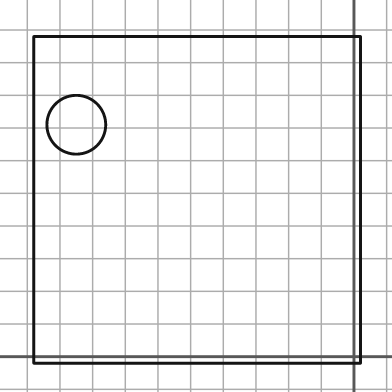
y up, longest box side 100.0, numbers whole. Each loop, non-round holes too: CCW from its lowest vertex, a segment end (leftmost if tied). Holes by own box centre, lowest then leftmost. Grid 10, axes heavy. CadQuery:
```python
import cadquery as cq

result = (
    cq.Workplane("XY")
    .moveTo(-98.0, -2.0)
    .lineTo(2.0, -2.0)
    .lineTo(2.0, 98.0)
    .lineTo(-98.0, 98.0)
    .close()
    .moveTo(-85.0, 71.0)
    .circle(9.0)
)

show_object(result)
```